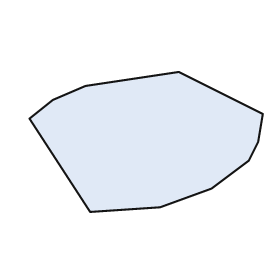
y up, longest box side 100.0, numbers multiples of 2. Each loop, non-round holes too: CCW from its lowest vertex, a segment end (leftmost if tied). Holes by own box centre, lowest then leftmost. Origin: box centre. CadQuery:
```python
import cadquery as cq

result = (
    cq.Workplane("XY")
    .moveTo(-24.0, -30.0)
    .lineTo(6.0, -28.0)
    .lineTo(28.0, -20.0)
    .lineTo(44.0, -8.0)
    .lineTo(48.0, 0.0)
    .lineTo(50.0, 12.0)
    .lineTo(14.0, 30.0)
    .lineTo(-26.0, 24.0)
    .lineTo(-40.0, 18.0)
    .lineTo(-50.0, 10.0)
    .close()
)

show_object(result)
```